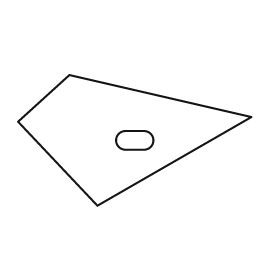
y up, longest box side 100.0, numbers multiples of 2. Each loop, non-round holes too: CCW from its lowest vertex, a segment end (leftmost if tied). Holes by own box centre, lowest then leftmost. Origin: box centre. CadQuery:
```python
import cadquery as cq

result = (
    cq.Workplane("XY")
    .moveTo(-16.0, -28.0)
    .lineTo(50.0, 10.0)
    .lineTo(-28.0, 28.0)
    .lineTo(-50.0, 8.0)
    .close()
    .moveTo(-4.0, -4.0)
    .lineTo(4.0, -4.0)
    .threePointArc((8.0, 0.0), (4.0, 4.0))
    .lineTo(-4.0, 4.0)
    .threePointArc((-8.0, 0.0), (-4.0, -4.0))
    .close()
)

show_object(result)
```